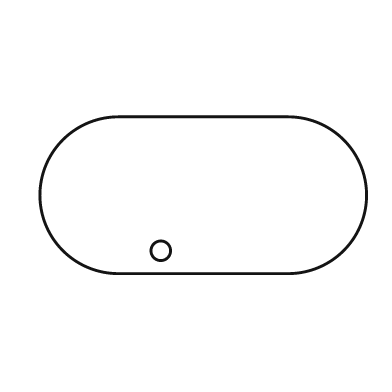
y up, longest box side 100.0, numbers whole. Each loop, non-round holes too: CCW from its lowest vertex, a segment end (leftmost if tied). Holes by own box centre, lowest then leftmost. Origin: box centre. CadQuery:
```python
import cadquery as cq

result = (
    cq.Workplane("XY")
    .moveTo(-26.0, -24.0)
    .lineTo(26.0, -24.0)
    .threePointArc((50.0, 0.0), (26.0, 24.0))
    .lineTo(-26.0, 24.0)
    .threePointArc((-50.0, 0.0), (-26.0, -24.0))
    .close()
    .moveTo(-13.0, -17.0)
    .circle(3.0)
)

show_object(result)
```